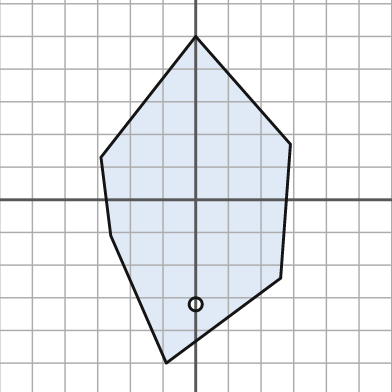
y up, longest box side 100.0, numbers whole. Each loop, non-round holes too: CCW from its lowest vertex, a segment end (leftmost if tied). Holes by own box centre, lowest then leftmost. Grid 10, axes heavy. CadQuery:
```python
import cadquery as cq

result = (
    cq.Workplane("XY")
    .moveTo(-9.0, -50.0)
    .lineTo(26.0, -24.0)
    .lineTo(29.0, 17.0)
    .lineTo(0.0, 50.0)
    .lineTo(-29.0, 13.0)
    .lineTo(-26.0, -11.0)
    .close()
    .moveTo(0.0, -32.0)
    .circle(2.0)
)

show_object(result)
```